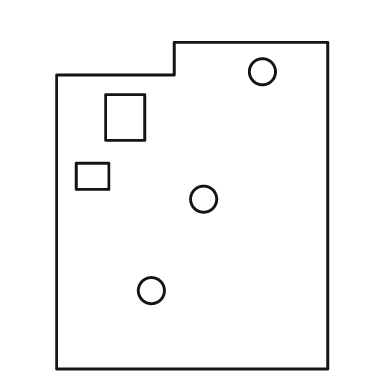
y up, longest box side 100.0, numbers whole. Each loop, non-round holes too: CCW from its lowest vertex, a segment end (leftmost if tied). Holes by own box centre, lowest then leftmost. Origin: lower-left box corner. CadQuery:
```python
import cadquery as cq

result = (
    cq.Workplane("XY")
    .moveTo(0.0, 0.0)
    .lineTo(83.0, 0.0)
    .lineTo(83.0, 100.0)
    .lineTo(36.0, 100.0)
    .lineTo(36.0, 90.0)
    .lineTo(0.0, 90.0)
    .close()
    .moveTo(29.0, 24.0)
    .circle(4.0)
    .moveTo(45.0, 52.0)
    .circle(4.0)
    .moveTo(6.0, 55.0)
    .lineTo(16.0, 55.0)
    .lineTo(16.0, 63.0)
    .lineTo(6.0, 63.0)
    .close()
    .moveTo(15.0, 70.0)
    .lineTo(27.0, 70.0)
    .lineTo(27.0, 84.0)
    .lineTo(15.0, 84.0)
    .close()
    .moveTo(63.0, 91.0)
    .circle(4.0)
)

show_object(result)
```